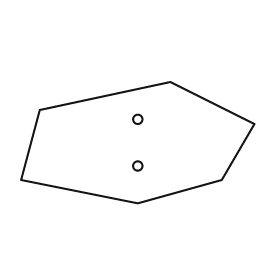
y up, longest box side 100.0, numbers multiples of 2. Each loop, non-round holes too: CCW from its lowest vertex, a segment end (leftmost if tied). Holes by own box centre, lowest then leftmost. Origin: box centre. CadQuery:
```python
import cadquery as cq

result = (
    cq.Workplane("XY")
    .moveTo(0.0, -26.0)
    .lineTo(36.0, -16.0)
    .lineTo(50.0, 8.0)
    .lineTo(14.0, 26.0)
    .lineTo(-42.0, 14.0)
    .lineTo(-50.0, -16.0)
    .close()
    .moveTo(0.0, -10.0)
    .circle(2.0)
    .moveTo(0.0, 10.0)
    .circle(2.0)
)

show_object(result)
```